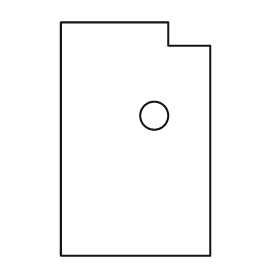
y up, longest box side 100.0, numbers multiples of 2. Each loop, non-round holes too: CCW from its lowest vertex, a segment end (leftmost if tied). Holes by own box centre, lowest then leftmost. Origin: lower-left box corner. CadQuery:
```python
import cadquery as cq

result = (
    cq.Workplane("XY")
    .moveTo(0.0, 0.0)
    .lineTo(64.0, 0.0)
    .lineTo(64.0, 90.0)
    .lineTo(46.0, 90.0)
    .lineTo(46.0, 100.0)
    .lineTo(0.0, 100.0)
    .close()
    .moveTo(40.0, 60.0)
    .circle(6.0)
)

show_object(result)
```